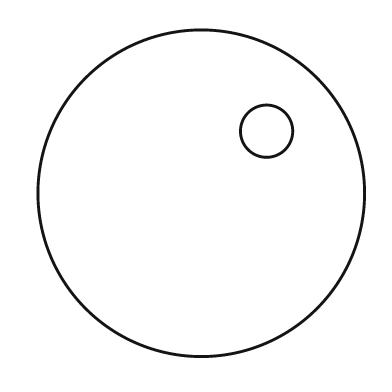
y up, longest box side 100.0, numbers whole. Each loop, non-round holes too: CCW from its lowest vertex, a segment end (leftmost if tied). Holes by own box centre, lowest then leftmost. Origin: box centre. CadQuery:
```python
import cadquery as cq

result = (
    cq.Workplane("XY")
    .moveTo(0.0, 0.0)
    .circle(50.0)
    .moveTo(20.0, 19.0)
    .circle(8.0)
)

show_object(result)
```